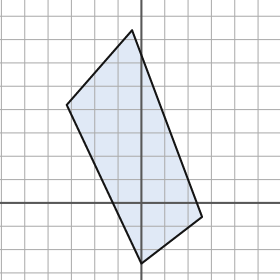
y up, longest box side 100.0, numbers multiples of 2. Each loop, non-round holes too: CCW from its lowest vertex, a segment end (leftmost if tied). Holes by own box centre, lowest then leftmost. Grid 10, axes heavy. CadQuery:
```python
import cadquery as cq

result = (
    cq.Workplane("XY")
    .moveTo(0.0, -26.0)
    .lineTo(26.0, -6.0)
    .lineTo(-4.0, 74.0)
    .lineTo(-32.0, 42.0)
    .close()
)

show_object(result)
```